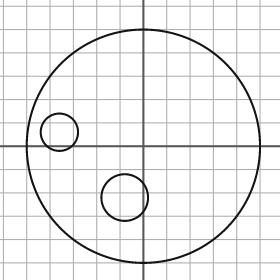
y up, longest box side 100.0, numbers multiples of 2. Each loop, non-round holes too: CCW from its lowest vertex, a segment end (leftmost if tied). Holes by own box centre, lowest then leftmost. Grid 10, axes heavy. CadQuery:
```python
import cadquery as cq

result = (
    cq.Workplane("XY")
    .moveTo(0.0, 0.0)
    .circle(50.0)
    .moveTo(-8.0, -22.0)
    .circle(10.0)
    .moveTo(-36.0, 6.0)
    .circle(8.0)
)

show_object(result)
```